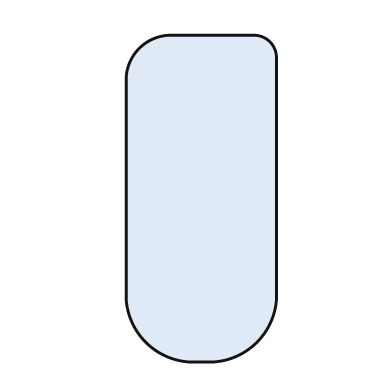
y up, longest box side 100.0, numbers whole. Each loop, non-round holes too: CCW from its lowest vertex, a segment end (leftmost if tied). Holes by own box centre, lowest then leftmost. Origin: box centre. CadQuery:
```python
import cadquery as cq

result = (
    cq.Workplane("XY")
    .moveTo(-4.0, -50.0)
    .lineTo(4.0, -50.0)
    .threePointArc((17.0, -44.0), (23.0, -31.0))
    .lineTo(23.0, 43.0)
    .threePointArc((21.0, 48.0), (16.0, 50.0))
    .lineTo(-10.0, 50.0)
    .threePointArc((-19.0, 46.0), (-23.0, 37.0))
    .lineTo(-23.0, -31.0)
    .threePointArc((-17.0, -44.0), (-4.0, -50.0))
    .close()
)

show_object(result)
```